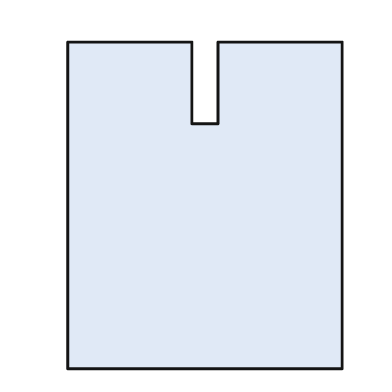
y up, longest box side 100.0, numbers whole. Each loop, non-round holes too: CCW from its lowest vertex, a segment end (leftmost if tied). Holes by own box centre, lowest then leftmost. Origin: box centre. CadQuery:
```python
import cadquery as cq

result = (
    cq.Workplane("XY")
    .moveTo(-42.0, -50.0)
    .lineTo(42.0, -50.0)
    .lineTo(42.0, 50.0)
    .lineTo(4.0, 50.0)
    .lineTo(4.0, 25.0)
    .lineTo(-4.0, 25.0)
    .lineTo(-4.0, 50.0)
    .lineTo(-42.0, 50.0)
    .close()
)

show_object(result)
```